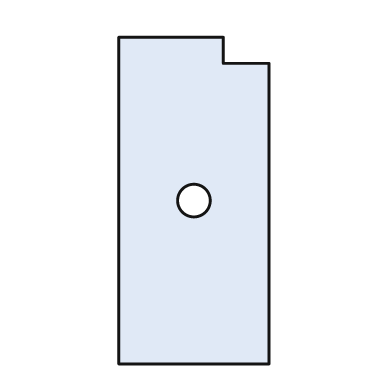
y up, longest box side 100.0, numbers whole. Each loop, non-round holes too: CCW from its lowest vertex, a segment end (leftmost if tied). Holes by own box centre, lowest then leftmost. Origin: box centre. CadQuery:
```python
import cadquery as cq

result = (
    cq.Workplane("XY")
    .moveTo(-23.0, -50.0)
    .lineTo(23.0, -50.0)
    .lineTo(23.0, 42.0)
    .lineTo(9.0, 42.0)
    .lineTo(9.0, 50.0)
    .lineTo(-23.0, 50.0)
    .close()
    .moveTo(0.0, 0.0)
    .circle(5.0)
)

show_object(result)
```